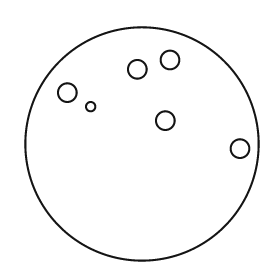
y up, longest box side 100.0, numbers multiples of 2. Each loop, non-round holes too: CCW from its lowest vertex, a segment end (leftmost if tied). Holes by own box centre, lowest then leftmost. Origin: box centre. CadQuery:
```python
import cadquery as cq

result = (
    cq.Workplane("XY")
    .moveTo(0.0, 0.0)
    .circle(50.0)
    .moveTo(42.0, -2.0)
    .circle(4.0)
    .moveTo(10.0, 10.0)
    .circle(4.0)
    .moveTo(-22.0, 16.0)
    .circle(2.0)
    .moveTo(-32.0, 22.0)
    .circle(4.0)
    .moveTo(-2.0, 32.0)
    .circle(4.0)
    .moveTo(12.0, 36.0)
    .circle(4.0)
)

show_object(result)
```